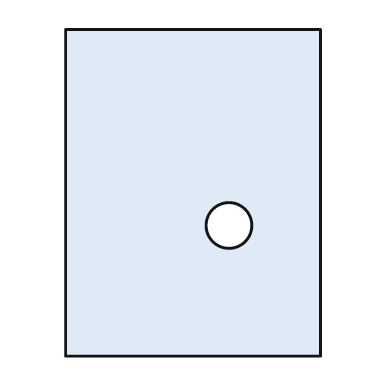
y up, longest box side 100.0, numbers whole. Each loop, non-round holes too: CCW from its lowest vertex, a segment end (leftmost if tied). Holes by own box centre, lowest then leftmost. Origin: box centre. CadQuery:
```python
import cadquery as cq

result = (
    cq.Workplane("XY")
    .moveTo(-39.0, -50.0)
    .lineTo(39.0, -50.0)
    .lineTo(39.0, 50.0)
    .lineTo(-39.0, 50.0)
    .close()
    .moveTo(11.0, -10.0)
    .circle(7.0)
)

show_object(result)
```